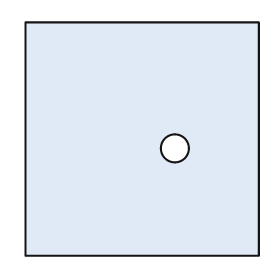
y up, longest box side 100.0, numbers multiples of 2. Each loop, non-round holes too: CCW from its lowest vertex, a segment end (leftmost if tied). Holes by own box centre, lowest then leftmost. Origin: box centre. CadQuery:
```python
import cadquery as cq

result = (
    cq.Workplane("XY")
    .moveTo(-50.0, -50.0)
    .lineTo(50.0, -50.0)
    .lineTo(50.0, 50.0)
    .lineTo(-50.0, 50.0)
    .close()
    .moveTo(14.0, -4.0)
    .circle(6.0)
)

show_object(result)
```